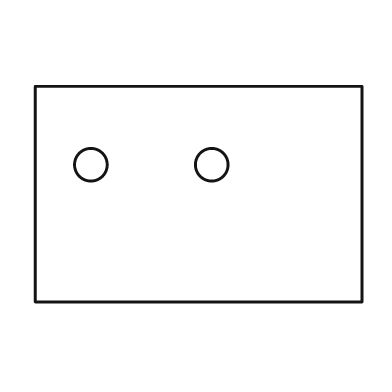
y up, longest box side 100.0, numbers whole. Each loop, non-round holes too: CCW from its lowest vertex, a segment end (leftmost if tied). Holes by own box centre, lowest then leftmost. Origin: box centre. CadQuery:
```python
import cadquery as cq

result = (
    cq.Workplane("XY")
    .moveTo(-50.0, -33.0)
    .lineTo(50.0, -33.0)
    .lineTo(50.0, 33.0)
    .lineTo(-50.0, 33.0)
    .close()
    .moveTo(-33.0, 9.0)
    .circle(5.0)
    .moveTo(4.0, 9.0)
    .circle(5.0)
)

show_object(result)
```